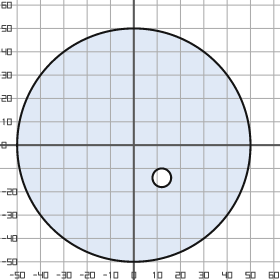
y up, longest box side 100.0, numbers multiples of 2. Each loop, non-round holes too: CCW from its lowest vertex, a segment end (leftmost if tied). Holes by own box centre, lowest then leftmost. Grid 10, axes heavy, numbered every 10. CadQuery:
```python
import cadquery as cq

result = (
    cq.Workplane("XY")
    .moveTo(0.0, 0.0)
    .circle(50.0)
    .moveTo(12.0, -14.0)
    .circle(4.0)
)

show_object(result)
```